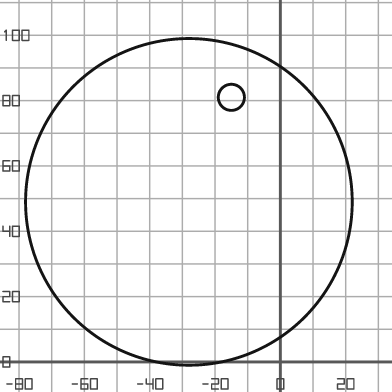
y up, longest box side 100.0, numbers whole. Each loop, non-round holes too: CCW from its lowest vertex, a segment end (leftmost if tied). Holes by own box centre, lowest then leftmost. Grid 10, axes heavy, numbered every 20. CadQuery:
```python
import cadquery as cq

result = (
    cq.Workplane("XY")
    .moveTo(-28.0, 49.0)
    .circle(50.0)
    .moveTo(-15.0, 81.0)
    .circle(4.0)
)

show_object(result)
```